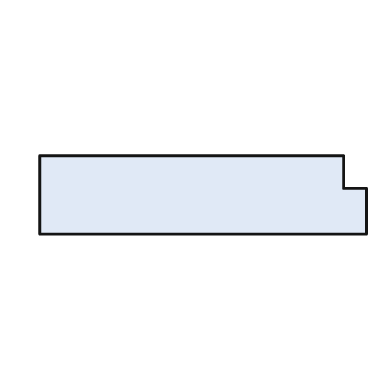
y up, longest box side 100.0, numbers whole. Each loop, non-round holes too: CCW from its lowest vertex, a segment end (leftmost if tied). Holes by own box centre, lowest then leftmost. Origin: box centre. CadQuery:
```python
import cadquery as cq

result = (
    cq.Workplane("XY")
    .moveTo(-50.0, -12.0)
    .lineTo(50.0, -12.0)
    .lineTo(50.0, 2.0)
    .lineTo(43.0, 2.0)
    .lineTo(43.0, 12.0)
    .lineTo(-50.0, 12.0)
    .close()
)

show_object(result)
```